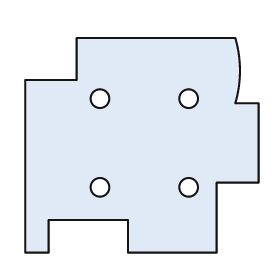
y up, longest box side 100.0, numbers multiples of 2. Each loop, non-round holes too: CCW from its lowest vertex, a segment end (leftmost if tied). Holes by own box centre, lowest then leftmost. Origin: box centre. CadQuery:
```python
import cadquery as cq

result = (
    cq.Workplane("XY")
    .moveTo(-50.0, -46.0)
    .lineTo(-40.0, -46.0)
    .lineTo(-40.0, -32.0)
    .lineTo(-6.0, -32.0)
    .lineTo(-6.0, -46.0)
    .lineTo(32.0, -46.0)
    .lineTo(32.0, -16.0)
    .lineTo(50.0, -16.0)
    .lineTo(50.0, 18.0)
    .lineTo(40.0, 18.0)
    .threePointArc((42.0, 32.0), (40.0, 46.0))
    .lineTo(-28.0, 46.0)
    .lineTo(-28.0, 28.0)
    .lineTo(-50.0, 28.0)
    .close()
    .moveTo(-18.0, -18.0)
    .circle(4.0)
    .moveTo(20.0, -18.0)
    .circle(4.0)
    .moveTo(-18.0, 20.0)
    .circle(4.0)
    .moveTo(20.0, 20.0)
    .circle(4.0)
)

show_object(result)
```